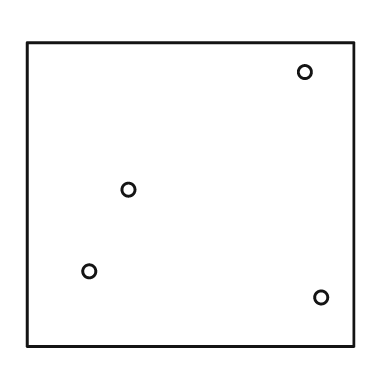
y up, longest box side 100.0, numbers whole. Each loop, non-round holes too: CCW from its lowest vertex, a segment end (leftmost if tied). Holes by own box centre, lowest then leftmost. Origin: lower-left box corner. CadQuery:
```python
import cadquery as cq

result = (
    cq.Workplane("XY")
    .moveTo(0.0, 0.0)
    .lineTo(100.0, 0.0)
    .lineTo(100.0, 93.0)
    .lineTo(0.0, 93.0)
    .close()
    .moveTo(90.0, 15.0)
    .circle(2.0)
    .moveTo(19.0, 23.0)
    .circle(2.0)
    .moveTo(31.0, 48.0)
    .circle(2.0)
    .moveTo(85.0, 84.0)
    .circle(2.0)
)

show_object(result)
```